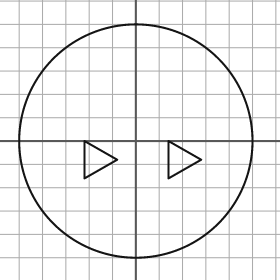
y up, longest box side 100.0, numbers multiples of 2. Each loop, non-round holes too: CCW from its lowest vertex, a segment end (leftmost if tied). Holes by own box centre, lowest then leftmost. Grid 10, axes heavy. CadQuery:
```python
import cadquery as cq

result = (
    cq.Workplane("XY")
    .moveTo(0.0, 0.0)
    .circle(50.0)
    .moveTo(-22.0, -16.0)
    .lineTo(-8.0, -8.0)
    .lineTo(-22.0, 0.0)
    .close()
    .moveTo(14.0, -16.0)
    .lineTo(28.0, -8.0)
    .lineTo(14.0, 0.0)
    .close()
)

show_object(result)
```